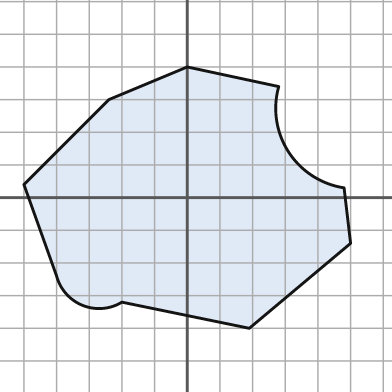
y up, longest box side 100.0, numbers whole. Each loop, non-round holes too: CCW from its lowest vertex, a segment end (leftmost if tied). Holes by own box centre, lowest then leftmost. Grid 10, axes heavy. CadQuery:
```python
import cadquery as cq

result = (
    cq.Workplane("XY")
    .moveTo(19.0, -40.0)
    .lineTo(50.0, -14.0)
    .lineTo(48.0, 3.0)
    .threePointArc((31.0, 14.0), (28.0, 34.0))
    .lineTo(0.0, 40.0)
    .lineTo(-24.0, 30.0)
    .lineTo(-50.0, 4.0)
    .lineTo(-40.0, -24.0)
    .threePointArc((-32.0, -33.0), (-20.0, -32.0))
    .close()
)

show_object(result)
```